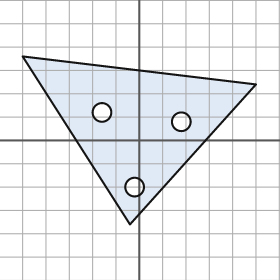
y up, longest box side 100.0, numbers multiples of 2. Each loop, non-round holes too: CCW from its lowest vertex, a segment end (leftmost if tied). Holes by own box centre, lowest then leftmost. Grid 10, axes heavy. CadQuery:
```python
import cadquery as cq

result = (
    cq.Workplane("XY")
    .moveTo(-4.0, -36.0)
    .lineTo(50.0, 24.0)
    .lineTo(-50.0, 36.0)
    .close()
    .moveTo(-2.0, -20.0)
    .circle(4.0)
    .moveTo(18.0, 8.0)
    .circle(4.0)
    .moveTo(-16.0, 12.0)
    .circle(4.0)
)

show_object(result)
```